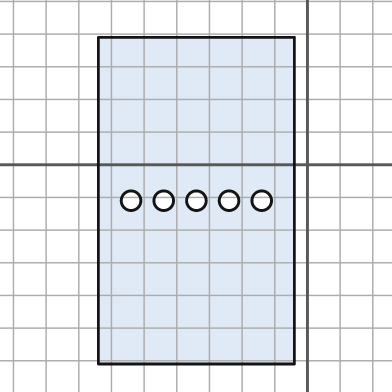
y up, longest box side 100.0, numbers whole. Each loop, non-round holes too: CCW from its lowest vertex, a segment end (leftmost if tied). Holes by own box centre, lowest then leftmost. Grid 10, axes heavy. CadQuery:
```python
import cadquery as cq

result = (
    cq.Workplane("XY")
    .moveTo(-64.0, -61.0)
    .lineTo(-4.0, -61.0)
    .lineTo(-4.0, 39.0)
    .lineTo(-64.0, 39.0)
    .close()
    .moveTo(-54.0, -11.0)
    .circle(3.0)
    .moveTo(-44.0, -11.0)
    .circle(3.0)
    .moveTo(-34.0, -11.0)
    .circle(3.0)
    .moveTo(-24.0, -11.0)
    .circle(3.0)
    .moveTo(-14.0, -11.0)
    .circle(3.0)
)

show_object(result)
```